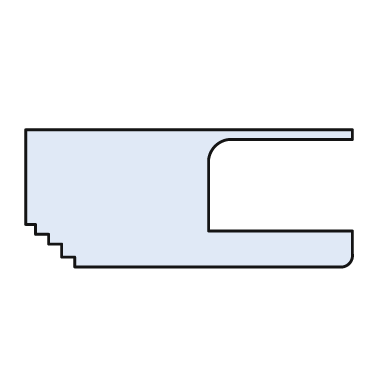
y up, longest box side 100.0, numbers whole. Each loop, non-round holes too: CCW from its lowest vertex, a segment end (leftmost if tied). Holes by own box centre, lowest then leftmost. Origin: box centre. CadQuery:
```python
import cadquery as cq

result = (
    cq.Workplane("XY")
    .moveTo(-35.0, -21.0)
    .lineTo(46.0, -21.0)
    .threePointArc((49.0, -20.0), (50.0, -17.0))
    .lineTo(50.0, -10.0)
    .lineTo(6.0, -10.0)
    .lineTo(6.0, 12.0)
    .threePointArc((8.0, 16.0), (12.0, 18.0))
    .lineTo(50.0, 18.0)
    .lineTo(50.0, 21.0)
    .lineTo(-50.0, 21.0)
    .lineTo(-50.0, -8.0)
    .lineTo(-47.0, -8.0)
    .lineTo(-47.0, -11.0)
    .lineTo(-43.0, -11.0)
    .lineTo(-43.0, -14.0)
    .lineTo(-39.0, -14.0)
    .lineTo(-39.0, -18.0)
    .lineTo(-35.0, -18.0)
    .close()
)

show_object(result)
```